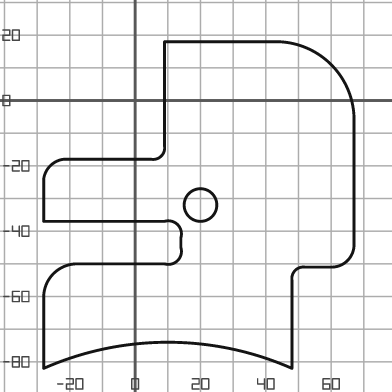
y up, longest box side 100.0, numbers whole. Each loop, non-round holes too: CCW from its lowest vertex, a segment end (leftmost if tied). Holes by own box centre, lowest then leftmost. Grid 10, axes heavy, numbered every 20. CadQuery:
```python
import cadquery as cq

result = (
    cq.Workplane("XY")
    .moveTo(-28.0, -82.0)
    .threePointArc((10.0, -74.0), (48.0, -82.0))
    .lineTo(48.0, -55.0)
    .threePointArc((49.0, -52.0), (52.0, -51.0))
    .lineTo(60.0, -51.0)
    .threePointArc((65.0, -49.0), (67.0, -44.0))
    .lineTo(67.0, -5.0)
    .threePointArc((60.0, 11.0), (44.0, 18.0))
    .lineTo(9.0, 18.0)
    .lineTo(9.0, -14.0)
    .threePointArc((8.0, -17.0), (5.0, -18.0))
    .lineTo(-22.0, -18.0)
    .threePointArc((-26.0, -20.0), (-28.0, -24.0))
    .lineTo(-28.0, -37.0)
    .lineTo(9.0, -37.0)
    .threePointArc((13.0, -38.0), (14.0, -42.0))
    .lineTo(14.0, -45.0)
    .threePointArc((13.0, -49.0), (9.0, -50.0))
    .lineTo(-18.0, -50.0)
    .threePointArc((-25.0, -53.0), (-28.0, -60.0))
    .close()
    .moveTo(20.0, -32.0)
    .circle(5.0)
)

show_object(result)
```